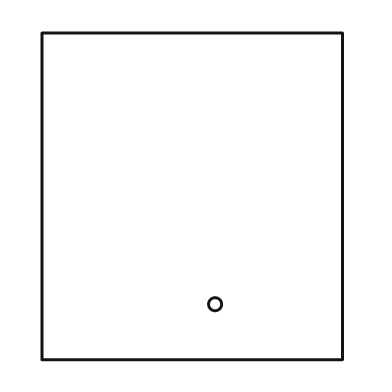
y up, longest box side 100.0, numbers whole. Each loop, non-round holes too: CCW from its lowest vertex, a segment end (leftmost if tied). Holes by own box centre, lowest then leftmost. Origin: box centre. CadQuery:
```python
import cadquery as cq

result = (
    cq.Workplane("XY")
    .moveTo(-46.0, -50.0)
    .lineTo(46.0, -50.0)
    .lineTo(46.0, 50.0)
    .lineTo(-46.0, 50.0)
    .close()
    .moveTo(7.0, -33.0)
    .circle(2.0)
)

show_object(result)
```